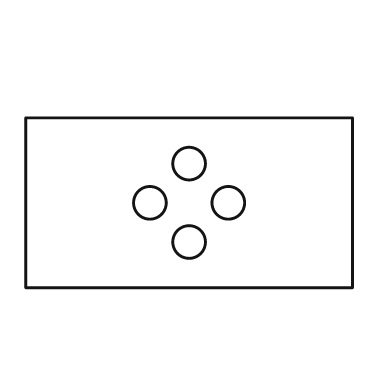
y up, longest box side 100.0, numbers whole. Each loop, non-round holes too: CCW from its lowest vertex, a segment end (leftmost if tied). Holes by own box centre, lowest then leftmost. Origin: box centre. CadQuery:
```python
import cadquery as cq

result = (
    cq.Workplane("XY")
    .moveTo(-50.0, -26.0)
    .lineTo(50.0, -26.0)
    .lineTo(50.0, 26.0)
    .lineTo(-50.0, 26.0)
    .close()
    .moveTo(0.0, -12.0)
    .circle(5.0)
    .moveTo(-12.0, 0.0)
    .circle(5.0)
    .moveTo(12.0, 0.0)
    .circle(5.0)
    .moveTo(0.0, 12.0)
    .circle(5.0)
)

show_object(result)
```